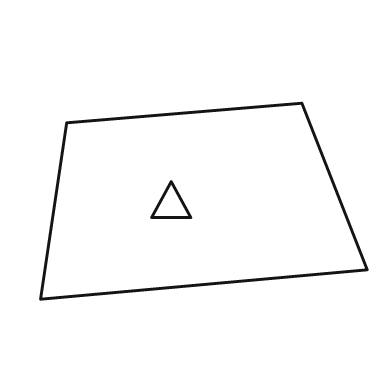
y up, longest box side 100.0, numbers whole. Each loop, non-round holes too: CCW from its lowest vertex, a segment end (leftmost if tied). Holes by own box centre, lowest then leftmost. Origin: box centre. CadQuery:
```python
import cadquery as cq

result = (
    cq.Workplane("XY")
    .moveTo(-50.0, -30.0)
    .lineTo(50.0, -21.0)
    .lineTo(30.0, 30.0)
    .lineTo(-42.0, 24.0)
    .close()
    .moveTo(-16.0, -5.0)
    .lineTo(-4.0, -5.0)
    .lineTo(-10.0, 6.0)
    .close()
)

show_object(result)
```